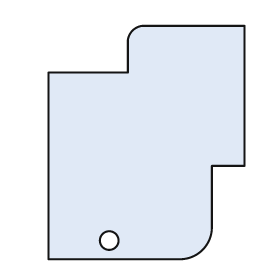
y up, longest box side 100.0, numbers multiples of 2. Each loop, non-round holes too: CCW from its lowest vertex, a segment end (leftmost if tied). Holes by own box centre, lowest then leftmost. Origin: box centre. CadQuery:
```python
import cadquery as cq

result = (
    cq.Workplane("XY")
    .moveTo(-42.0, -50.0)
    .lineTo(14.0, -50.0)
    .threePointArc((24.0, -46.0), (28.0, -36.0))
    .lineTo(28.0, -10.0)
    .lineTo(42.0, -10.0)
    .lineTo(42.0, 50.0)
    .lineTo(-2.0, 50.0)
    .threePointArc((-6.0, 48.0), (-8.0, 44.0))
    .lineTo(-8.0, 30.0)
    .lineTo(-42.0, 30.0)
    .close()
    .moveTo(-16.0, -42.0)
    .circle(4.0)
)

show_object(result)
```